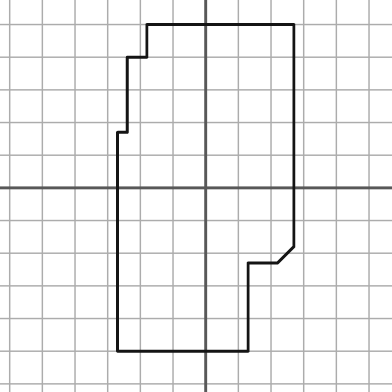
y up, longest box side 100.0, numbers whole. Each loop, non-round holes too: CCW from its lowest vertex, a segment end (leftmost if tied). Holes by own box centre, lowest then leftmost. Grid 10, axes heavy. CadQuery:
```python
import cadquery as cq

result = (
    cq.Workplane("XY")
    .moveTo(-27.0, -50.0)
    .lineTo(13.0, -50.0)
    .lineTo(13.0, -23.0)
    .lineTo(22.0, -23.0)
    .lineTo(27.0, -18.0)
    .lineTo(27.0, 50.0)
    .lineTo(-18.0, 50.0)
    .lineTo(-18.0, 40.0)
    .lineTo(-24.0, 40.0)
    .lineTo(-24.0, 17.0)
    .lineTo(-27.0, 17.0)
    .close()
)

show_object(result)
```